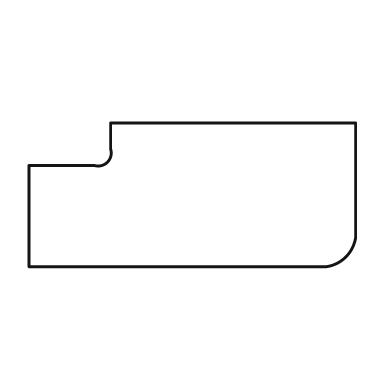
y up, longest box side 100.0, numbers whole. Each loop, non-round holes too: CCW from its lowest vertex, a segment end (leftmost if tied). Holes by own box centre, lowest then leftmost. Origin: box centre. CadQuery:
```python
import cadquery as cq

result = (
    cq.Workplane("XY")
    .moveTo(-50.0, -22.0)
    .lineTo(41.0, -22.0)
    .threePointArc((47.0, -19.0), (50.0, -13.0))
    .lineTo(50.0, 22.0)
    .lineTo(-25.0, 22.0)
    .lineTo(-25.0, 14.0)
    .threePointArc((-26.0, 10.0), (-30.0, 9.0))
    .lineTo(-50.0, 9.0)
    .close()
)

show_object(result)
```